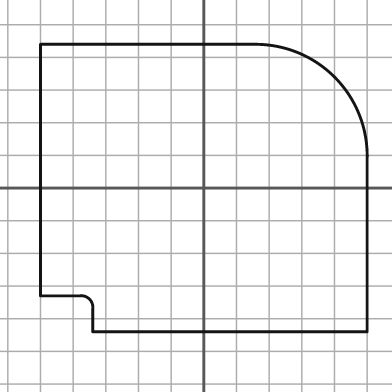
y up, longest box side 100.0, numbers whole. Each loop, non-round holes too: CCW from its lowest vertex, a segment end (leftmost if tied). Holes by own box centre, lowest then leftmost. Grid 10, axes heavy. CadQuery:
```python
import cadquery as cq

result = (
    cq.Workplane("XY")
    .moveTo(-34.0, -44.0)
    .lineTo(50.0, -44.0)
    .lineTo(50.0, 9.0)
    .threePointArc((40.0, 34.0), (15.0, 44.0))
    .lineTo(-50.0, 44.0)
    .lineTo(-50.0, -33.0)
    .lineTo(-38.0, -33.0)
    .threePointArc((-35.0, -34.0), (-34.0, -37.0))
    .close()
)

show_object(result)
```